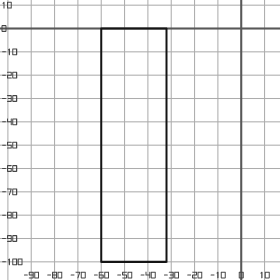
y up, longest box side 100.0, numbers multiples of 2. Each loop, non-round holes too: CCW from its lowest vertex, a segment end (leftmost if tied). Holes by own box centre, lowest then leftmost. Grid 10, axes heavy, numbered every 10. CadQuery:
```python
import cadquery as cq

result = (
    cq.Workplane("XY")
    .moveTo(-60.0, -100.0)
    .lineTo(-32.0, -100.0)
    .lineTo(-32.0, 0.0)
    .lineTo(-60.0, 0.0)
    .close()
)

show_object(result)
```